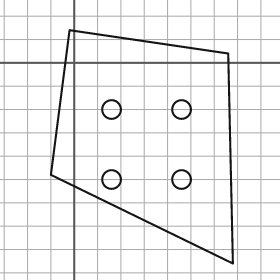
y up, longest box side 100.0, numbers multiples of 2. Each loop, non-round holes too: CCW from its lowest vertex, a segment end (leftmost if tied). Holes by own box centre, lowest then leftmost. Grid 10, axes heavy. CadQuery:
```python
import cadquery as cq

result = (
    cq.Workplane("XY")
    .moveTo(68.0, -86.0)
    .lineTo(66.0, 4.0)
    .lineTo(-2.0, 14.0)
    .lineTo(-10.0, -48.0)
    .close()
    .moveTo(16.0, -50.0)
    .circle(4.0)
    .moveTo(46.0, -50.0)
    .circle(4.0)
    .moveTo(16.0, -20.0)
    .circle(4.0)
    .moveTo(46.0, -20.0)
    .circle(4.0)
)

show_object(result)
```